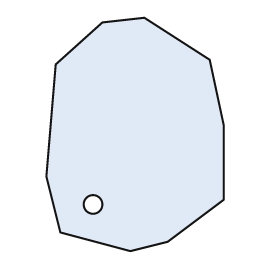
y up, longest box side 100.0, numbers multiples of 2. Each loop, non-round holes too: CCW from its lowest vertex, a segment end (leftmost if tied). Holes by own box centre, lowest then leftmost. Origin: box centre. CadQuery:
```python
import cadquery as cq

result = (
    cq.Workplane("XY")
    .moveTo(-2.0, -50.0)
    .lineTo(14.0, -46.0)
    .lineTo(38.0, -28.0)
    .lineTo(38.0, 4.0)
    .lineTo(32.0, 32.0)
    .lineTo(4.0, 50.0)
    .lineTo(-14.0, 48.0)
    .lineTo(-34.0, 30.0)
    .lineTo(-38.0, -18.0)
    .lineTo(-32.0, -42.0)
    .close()
    .moveTo(-18.0, -30.0)
    .circle(4.0)
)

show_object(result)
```